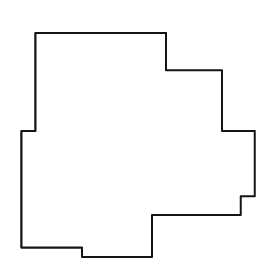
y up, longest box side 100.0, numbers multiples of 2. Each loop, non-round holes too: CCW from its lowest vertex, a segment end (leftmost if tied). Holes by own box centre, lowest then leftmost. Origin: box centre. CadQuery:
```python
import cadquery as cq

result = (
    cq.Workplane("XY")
    .moveTo(-24.0, -48.0)
    .lineTo(6.0, -48.0)
    .lineTo(6.0, -30.0)
    .lineTo(44.0, -30.0)
    .lineTo(44.0, -22.0)
    .lineTo(50.0, -22.0)
    .lineTo(50.0, 6.0)
    .lineTo(36.0, 6.0)
    .lineTo(36.0, 32.0)
    .lineTo(12.0, 32.0)
    .lineTo(12.0, 48.0)
    .lineTo(-44.0, 48.0)
    .lineTo(-44.0, 6.0)
    .lineTo(-50.0, 6.0)
    .lineTo(-50.0, -44.0)
    .lineTo(-24.0, -44.0)
    .close()
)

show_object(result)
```